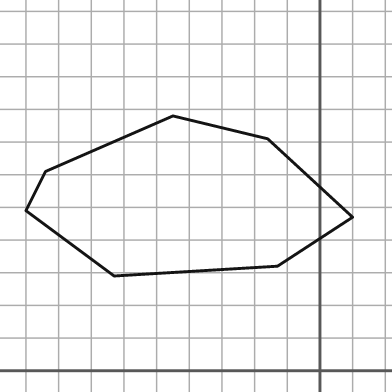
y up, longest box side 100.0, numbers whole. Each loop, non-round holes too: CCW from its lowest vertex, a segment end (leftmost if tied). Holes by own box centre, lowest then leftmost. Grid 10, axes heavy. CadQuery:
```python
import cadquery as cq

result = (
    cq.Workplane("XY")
    .moveTo(-63.0, 29.0)
    .lineTo(-13.0, 32.0)
    .lineTo(10.0, 47.0)
    .lineTo(-16.0, 71.0)
    .lineTo(-45.0, 78.0)
    .lineTo(-84.0, 61.0)
    .lineTo(-90.0, 49.0)
    .close()
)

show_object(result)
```